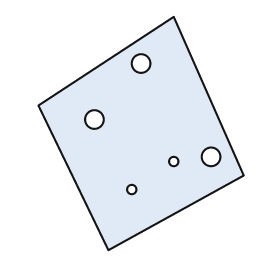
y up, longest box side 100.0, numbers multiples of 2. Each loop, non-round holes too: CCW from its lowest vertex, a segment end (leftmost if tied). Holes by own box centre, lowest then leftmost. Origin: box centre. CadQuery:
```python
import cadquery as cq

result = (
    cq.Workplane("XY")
    .moveTo(-14.0, -50.0)
    .lineTo(44.0, -18.0)
    .lineTo(14.0, 50.0)
    .lineTo(-44.0, 12.0)
    .close()
    .moveTo(-4.0, -24.0)
    .circle(2.0)
    .moveTo(14.0, -12.0)
    .circle(2.0)
    .moveTo(30.0, -10.0)
    .circle(4.0)
    .moveTo(-20.0, 6.0)
    .circle(4.0)
    .moveTo(0.0, 30.0)
    .circle(4.0)
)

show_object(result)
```